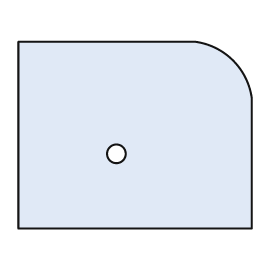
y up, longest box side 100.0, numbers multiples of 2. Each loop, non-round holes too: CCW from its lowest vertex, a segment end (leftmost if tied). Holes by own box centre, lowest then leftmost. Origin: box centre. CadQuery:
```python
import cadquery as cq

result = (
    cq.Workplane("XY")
    .moveTo(-50.0, -40.0)
    .lineTo(50.0, -40.0)
    .lineTo(50.0, 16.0)
    .threePointArc((42.0, 32.0), (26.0, 40.0))
    .lineTo(-50.0, 40.0)
    .close()
    .moveTo(-8.0, -8.0)
    .circle(4.0)
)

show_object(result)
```